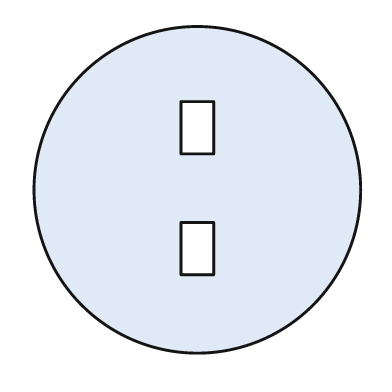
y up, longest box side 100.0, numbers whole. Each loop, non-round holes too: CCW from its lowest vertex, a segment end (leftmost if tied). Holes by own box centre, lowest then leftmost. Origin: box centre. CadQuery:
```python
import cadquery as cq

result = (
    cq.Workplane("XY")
    .moveTo(0.0, 0.0)
    .circle(50.0)
    .moveTo(-5.0, -26.0)
    .lineTo(5.0, -26.0)
    .lineTo(5.0, -10.0)
    .lineTo(-5.0, -10.0)
    .close()
    .moveTo(-5.0, 11.0)
    .lineTo(5.0, 11.0)
    .lineTo(5.0, 27.0)
    .lineTo(-5.0, 27.0)
    .close()
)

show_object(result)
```